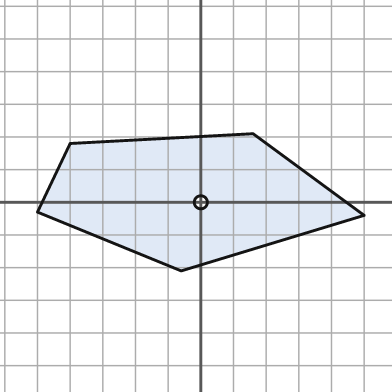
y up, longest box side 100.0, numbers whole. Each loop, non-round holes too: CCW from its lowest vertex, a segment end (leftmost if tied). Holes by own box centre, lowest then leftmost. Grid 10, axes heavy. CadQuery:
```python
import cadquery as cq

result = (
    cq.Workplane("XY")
    .moveTo(-6.0, -21.0)
    .lineTo(50.0, -4.0)
    .lineTo(16.0, 21.0)
    .lineTo(-40.0, 18.0)
    .lineTo(-50.0, -3.0)
    .close()
    .moveTo(0.0, 0.0)
    .circle(2.0)
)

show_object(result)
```